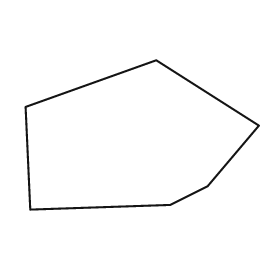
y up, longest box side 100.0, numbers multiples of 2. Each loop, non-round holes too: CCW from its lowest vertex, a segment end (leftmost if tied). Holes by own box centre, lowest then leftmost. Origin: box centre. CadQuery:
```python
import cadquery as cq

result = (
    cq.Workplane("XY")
    .moveTo(-48.0, -32.0)
    .lineTo(12.0, -30.0)
    .lineTo(28.0, -22.0)
    .lineTo(50.0, 4.0)
    .lineTo(6.0, 32.0)
    .lineTo(-50.0, 12.0)
    .close()
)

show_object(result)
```